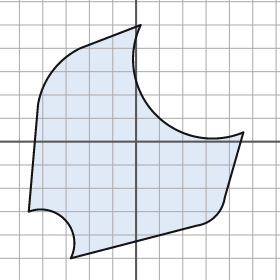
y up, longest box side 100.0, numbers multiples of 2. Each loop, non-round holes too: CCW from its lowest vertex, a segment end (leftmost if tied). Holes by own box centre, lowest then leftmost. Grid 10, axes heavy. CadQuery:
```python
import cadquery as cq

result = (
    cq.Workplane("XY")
    .moveTo(-28.0, -50.0)
    .lineTo(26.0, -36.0)
    .threePointArc((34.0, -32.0), (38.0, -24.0))
    .lineTo(46.0, 4.0)
    .threePointArc((8.0, 12.0), (2.0, 50.0))
    .lineTo(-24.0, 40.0)
    .threePointArc((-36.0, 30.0), (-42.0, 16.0))
    .lineTo(-46.0, -30.0)
    .threePointArc((-30.0, -34.0), (-28.0, -50.0))
    .close()
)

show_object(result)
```